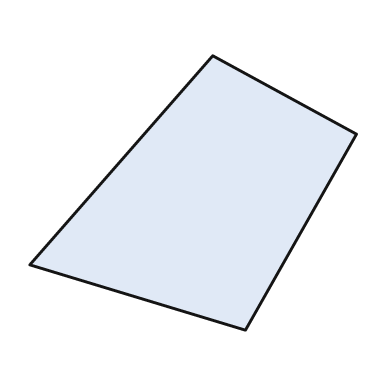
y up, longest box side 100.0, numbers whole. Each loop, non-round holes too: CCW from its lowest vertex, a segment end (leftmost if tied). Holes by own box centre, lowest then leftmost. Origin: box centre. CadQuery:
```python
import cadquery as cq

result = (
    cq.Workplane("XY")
    .moveTo(16.0, -42.0)
    .lineTo(50.0, 18.0)
    .lineTo(6.0, 42.0)
    .lineTo(-50.0, -22.0)
    .close()
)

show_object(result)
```